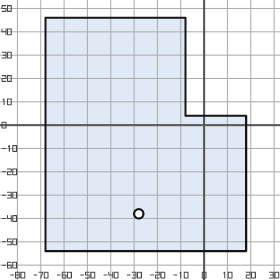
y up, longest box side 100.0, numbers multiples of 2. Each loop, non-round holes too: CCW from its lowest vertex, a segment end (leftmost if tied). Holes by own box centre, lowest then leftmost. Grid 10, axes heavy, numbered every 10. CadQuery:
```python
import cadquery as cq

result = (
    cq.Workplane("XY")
    .moveTo(-68.0, -54.0)
    .lineTo(18.0, -54.0)
    .lineTo(18.0, 4.0)
    .lineTo(-8.0, 4.0)
    .lineTo(-8.0, 46.0)
    .lineTo(-68.0, 46.0)
    .close()
    .moveTo(-28.0, -38.0)
    .circle(2.0)
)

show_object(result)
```